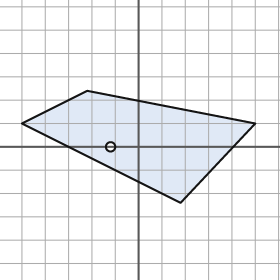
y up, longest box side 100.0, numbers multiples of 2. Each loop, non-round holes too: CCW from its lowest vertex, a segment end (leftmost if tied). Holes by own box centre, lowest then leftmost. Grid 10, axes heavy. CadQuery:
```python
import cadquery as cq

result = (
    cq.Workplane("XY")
    .moveTo(18.0, -24.0)
    .lineTo(50.0, 10.0)
    .lineTo(-22.0, 24.0)
    .lineTo(-50.0, 10.0)
    .close()
    .moveTo(-12.0, 0.0)
    .circle(2.0)
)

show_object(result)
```